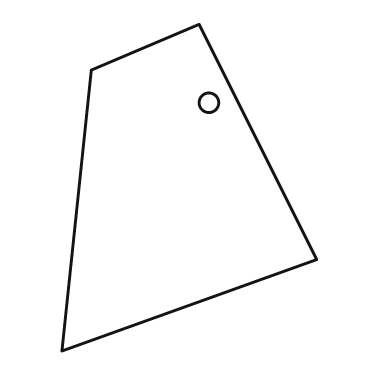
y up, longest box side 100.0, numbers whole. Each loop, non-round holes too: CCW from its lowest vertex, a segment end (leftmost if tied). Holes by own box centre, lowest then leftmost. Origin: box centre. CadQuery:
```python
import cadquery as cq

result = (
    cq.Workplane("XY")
    .moveTo(-39.0, -50.0)
    .lineTo(39.0, -22.0)
    .lineTo(3.0, 50.0)
    .lineTo(-30.0, 36.0)
    .close()
    .moveTo(6.0, 26.0)
    .circle(3.0)
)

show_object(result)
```